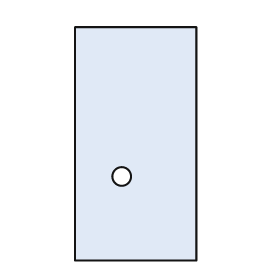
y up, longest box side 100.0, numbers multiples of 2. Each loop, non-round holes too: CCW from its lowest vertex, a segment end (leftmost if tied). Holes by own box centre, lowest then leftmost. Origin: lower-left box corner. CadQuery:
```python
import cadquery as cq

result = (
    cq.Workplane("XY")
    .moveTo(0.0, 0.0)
    .lineTo(52.0, 0.0)
    .lineTo(52.0, 100.0)
    .lineTo(0.0, 100.0)
    .close()
    .moveTo(20.0, 36.0)
    .circle(4.0)
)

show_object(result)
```